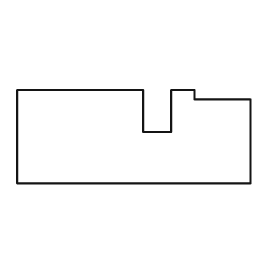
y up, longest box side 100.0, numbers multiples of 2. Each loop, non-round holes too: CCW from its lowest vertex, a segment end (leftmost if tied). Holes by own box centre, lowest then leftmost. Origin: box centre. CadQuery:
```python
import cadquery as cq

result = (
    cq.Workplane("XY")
    .moveTo(-50.0, -20.0)
    .lineTo(50.0, -20.0)
    .lineTo(50.0, 16.0)
    .lineTo(26.0, 16.0)
    .lineTo(26.0, 20.0)
    .lineTo(16.0, 20.0)
    .lineTo(16.0, 2.0)
    .lineTo(4.0, 2.0)
    .lineTo(4.0, 20.0)
    .lineTo(-50.0, 20.0)
    .close()
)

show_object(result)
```